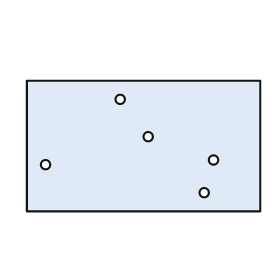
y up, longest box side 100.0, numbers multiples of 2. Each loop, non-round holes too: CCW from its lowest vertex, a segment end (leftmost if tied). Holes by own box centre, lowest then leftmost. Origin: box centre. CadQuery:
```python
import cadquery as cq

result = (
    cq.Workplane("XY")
    .moveTo(-50.0, -28.0)
    .lineTo(50.0, -28.0)
    .lineTo(50.0, 28.0)
    .lineTo(-50.0, 28.0)
    .close()
    .moveTo(26.0, -20.0)
    .circle(2.0)
    .moveTo(-42.0, -8.0)
    .circle(2.0)
    .moveTo(30.0, -6.0)
    .circle(2.0)
    .moveTo(2.0, 4.0)
    .circle(2.0)
    .moveTo(-10.0, 20.0)
    .circle(2.0)
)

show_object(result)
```